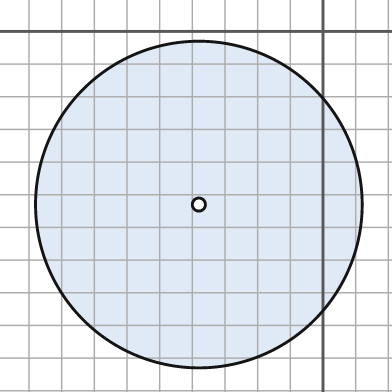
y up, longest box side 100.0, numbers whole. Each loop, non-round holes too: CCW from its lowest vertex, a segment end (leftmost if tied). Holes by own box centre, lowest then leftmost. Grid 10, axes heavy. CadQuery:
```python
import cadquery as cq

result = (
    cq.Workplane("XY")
    .moveTo(-38.0, -53.0)
    .circle(50.0)
    .moveTo(-38.0, -53.0)
    .circle(2.0)
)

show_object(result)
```